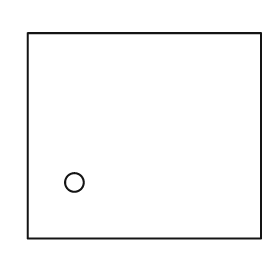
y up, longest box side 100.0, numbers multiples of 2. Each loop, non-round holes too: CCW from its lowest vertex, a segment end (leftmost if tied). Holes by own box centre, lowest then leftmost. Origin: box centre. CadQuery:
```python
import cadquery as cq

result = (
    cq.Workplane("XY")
    .moveTo(-50.0, -44.0)
    .lineTo(50.0, -44.0)
    .lineTo(50.0, 44.0)
    .lineTo(-50.0, 44.0)
    .close()
    .moveTo(-30.0, -20.0)
    .circle(4.0)
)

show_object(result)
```